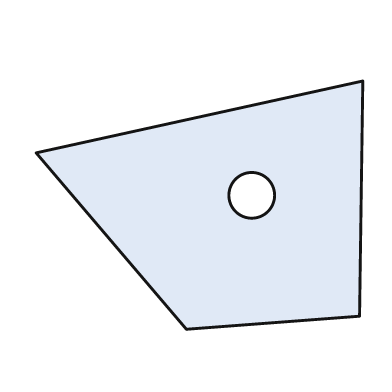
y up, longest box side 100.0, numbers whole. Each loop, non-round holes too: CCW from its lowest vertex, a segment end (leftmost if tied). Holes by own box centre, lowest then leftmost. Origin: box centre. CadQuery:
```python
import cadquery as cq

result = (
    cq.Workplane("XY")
    .moveTo(-4.0, -38.0)
    .lineTo(49.0, -34.0)
    .lineTo(50.0, 38.0)
    .lineTo(-50.0, 16.0)
    .close()
    .moveTo(16.0, 3.0)
    .circle(7.0)
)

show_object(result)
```